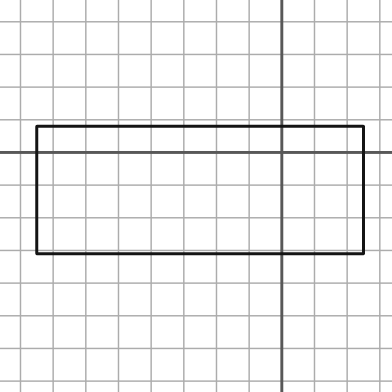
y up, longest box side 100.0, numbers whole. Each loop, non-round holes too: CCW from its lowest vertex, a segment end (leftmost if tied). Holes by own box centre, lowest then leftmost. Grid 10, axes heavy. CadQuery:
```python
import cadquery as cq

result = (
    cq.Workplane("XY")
    .moveTo(-75.0, -31.0)
    .lineTo(25.0, -31.0)
    .lineTo(25.0, 8.0)
    .lineTo(-75.0, 8.0)
    .close()
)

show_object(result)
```